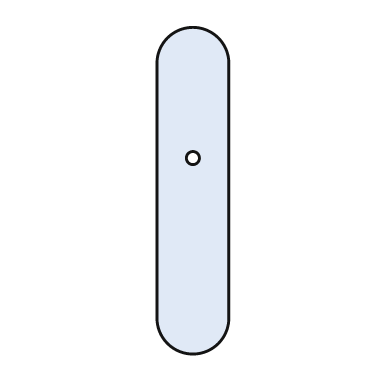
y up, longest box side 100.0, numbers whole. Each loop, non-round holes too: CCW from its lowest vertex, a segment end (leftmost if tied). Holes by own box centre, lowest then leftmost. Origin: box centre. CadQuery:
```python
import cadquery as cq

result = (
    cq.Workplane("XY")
    .moveTo(-11.0, -39.0)
    .threePointArc((0.0, -50.0), (11.0, -39.0))
    .lineTo(11.0, 39.0)
    .threePointArc((0.0, 50.0), (-11.0, 39.0))
    .close()
    .moveTo(0.0, 10.0)
    .circle(2.0)
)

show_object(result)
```